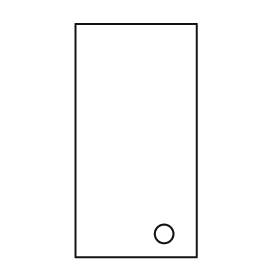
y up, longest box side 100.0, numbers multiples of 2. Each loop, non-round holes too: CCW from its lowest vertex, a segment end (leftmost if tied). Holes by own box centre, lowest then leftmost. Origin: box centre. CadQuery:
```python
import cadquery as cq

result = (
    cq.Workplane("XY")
    .moveTo(-26.0, -50.0)
    .lineTo(26.0, -50.0)
    .lineTo(26.0, 50.0)
    .lineTo(-26.0, 50.0)
    .close()
    .moveTo(12.0, -40.0)
    .circle(4.0)
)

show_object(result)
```